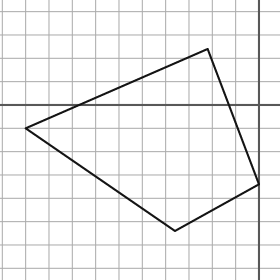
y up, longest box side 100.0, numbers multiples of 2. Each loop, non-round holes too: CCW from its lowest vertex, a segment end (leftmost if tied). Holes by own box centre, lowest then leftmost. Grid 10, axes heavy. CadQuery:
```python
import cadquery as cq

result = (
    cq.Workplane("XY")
    .moveTo(-36.0, -54.0)
    .lineTo(0.0, -34.0)
    .lineTo(-22.0, 24.0)
    .lineTo(-100.0, -10.0)
    .close()
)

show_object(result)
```